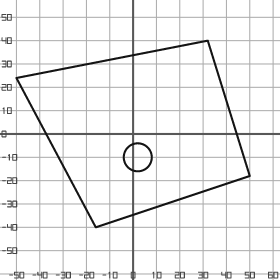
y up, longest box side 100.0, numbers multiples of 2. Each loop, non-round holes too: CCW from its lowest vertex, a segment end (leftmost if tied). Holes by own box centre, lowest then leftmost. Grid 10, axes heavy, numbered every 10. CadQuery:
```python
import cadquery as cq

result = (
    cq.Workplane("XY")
    .moveTo(-16.0, -40.0)
    .lineTo(50.0, -18.0)
    .lineTo(32.0, 40.0)
    .lineTo(-50.0, 24.0)
    .close()
    .moveTo(2.0, -10.0)
    .circle(6.0)
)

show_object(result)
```